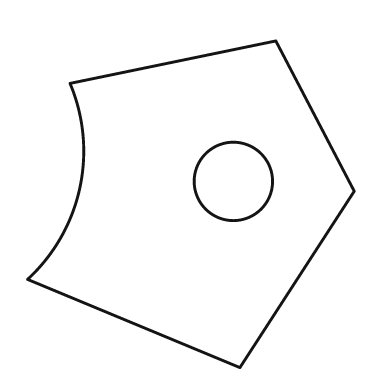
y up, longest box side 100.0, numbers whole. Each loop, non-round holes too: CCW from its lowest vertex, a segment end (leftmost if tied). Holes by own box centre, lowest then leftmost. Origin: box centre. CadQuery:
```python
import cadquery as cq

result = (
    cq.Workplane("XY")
    .moveTo(15.0, -50.0)
    .lineTo(50.0, 4.0)
    .lineTo(26.0, 50.0)
    .lineTo(-37.0, 37.0)
    .threePointArc((-34.0, 5.0), (-50.0, -23.0))
    .close()
    .moveTo(13.0, 7.0)
    .circle(12.0)
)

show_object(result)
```